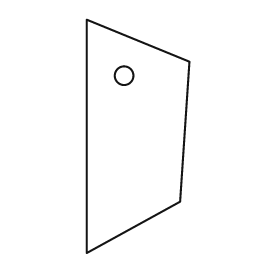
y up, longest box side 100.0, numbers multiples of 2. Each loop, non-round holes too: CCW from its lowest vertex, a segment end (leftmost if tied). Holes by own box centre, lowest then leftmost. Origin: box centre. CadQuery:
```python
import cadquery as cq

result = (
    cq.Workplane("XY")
    .moveTo(-22.0, -50.0)
    .lineTo(18.0, -28.0)
    .lineTo(22.0, 32.0)
    .lineTo(-22.0, 50.0)
    .close()
    .moveTo(-6.0, 26.0)
    .circle(4.0)
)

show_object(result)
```